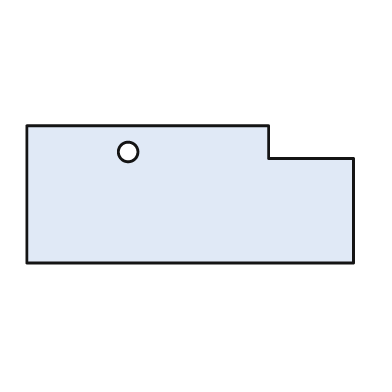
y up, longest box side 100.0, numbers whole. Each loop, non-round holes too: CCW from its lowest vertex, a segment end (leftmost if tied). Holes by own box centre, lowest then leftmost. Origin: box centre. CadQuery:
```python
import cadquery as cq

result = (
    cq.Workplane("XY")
    .moveTo(-50.0, -21.0)
    .lineTo(50.0, -21.0)
    .lineTo(50.0, 11.0)
    .lineTo(24.0, 11.0)
    .lineTo(24.0, 21.0)
    .lineTo(-50.0, 21.0)
    .close()
    .moveTo(-19.0, 13.0)
    .circle(3.0)
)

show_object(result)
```